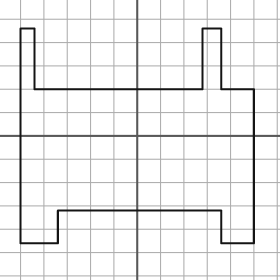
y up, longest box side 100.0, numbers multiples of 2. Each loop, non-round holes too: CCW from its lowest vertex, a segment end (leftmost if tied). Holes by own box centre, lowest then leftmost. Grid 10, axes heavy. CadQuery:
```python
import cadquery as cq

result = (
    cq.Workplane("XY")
    .moveTo(-50.0, -46.0)
    .lineTo(-34.0, -46.0)
    .lineTo(-34.0, -32.0)
    .lineTo(36.0, -32.0)
    .lineTo(36.0, -46.0)
    .lineTo(50.0, -46.0)
    .lineTo(50.0, 20.0)
    .lineTo(36.0, 20.0)
    .lineTo(36.0, 46.0)
    .lineTo(28.0, 46.0)
    .lineTo(28.0, 20.0)
    .lineTo(-44.0, 20.0)
    .lineTo(-44.0, 46.0)
    .lineTo(-50.0, 46.0)
    .close()
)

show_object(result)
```